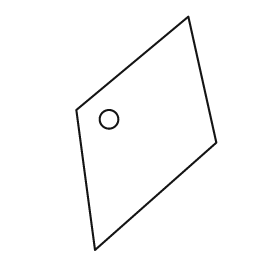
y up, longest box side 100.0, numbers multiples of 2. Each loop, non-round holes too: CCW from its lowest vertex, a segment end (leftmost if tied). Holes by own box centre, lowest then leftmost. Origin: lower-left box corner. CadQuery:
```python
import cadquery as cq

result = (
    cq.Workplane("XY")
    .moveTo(8.0, 0.0)
    .lineTo(60.0, 46.0)
    .lineTo(48.0, 100.0)
    .lineTo(0.0, 60.0)
    .close()
    .moveTo(14.0, 56.0)
    .circle(4.0)
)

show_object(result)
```